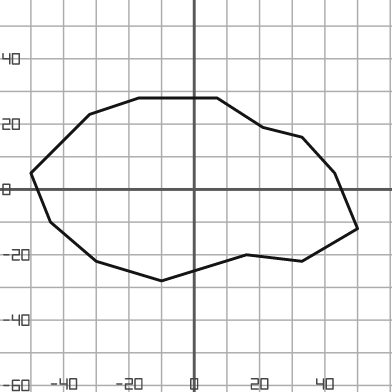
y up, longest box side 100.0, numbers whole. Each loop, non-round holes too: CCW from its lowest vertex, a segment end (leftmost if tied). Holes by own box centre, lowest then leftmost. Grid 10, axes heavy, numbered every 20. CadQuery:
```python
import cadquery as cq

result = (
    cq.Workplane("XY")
    .moveTo(-10.0, -28.0)
    .lineTo(16.0, -20.0)
    .lineTo(33.0, -22.0)
    .lineTo(50.0, -12.0)
    .lineTo(43.0, 5.0)
    .lineTo(33.0, 16.0)
    .lineTo(21.0, 19.0)
    .lineTo(7.0, 28.0)
    .lineTo(-17.0, 28.0)
    .lineTo(-32.0, 23.0)
    .lineTo(-50.0, 5.0)
    .lineTo(-44.0, -10.0)
    .lineTo(-30.0, -22.0)
    .close()
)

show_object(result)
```